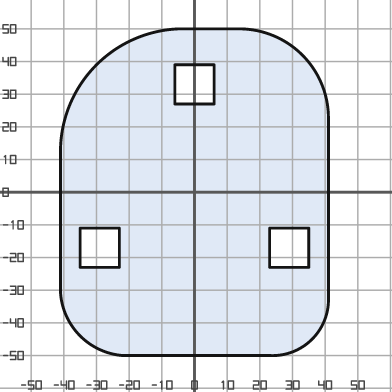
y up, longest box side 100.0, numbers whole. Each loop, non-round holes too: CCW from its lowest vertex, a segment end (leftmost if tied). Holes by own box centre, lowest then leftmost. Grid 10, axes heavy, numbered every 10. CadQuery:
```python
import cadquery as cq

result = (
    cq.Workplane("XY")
    .moveTo(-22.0, -50.0)
    .lineTo(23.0, -50.0)
    .threePointArc((36.0, -45.0), (41.0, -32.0))
    .lineTo(41.0, 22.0)
    .threePointArc((33.0, 42.0), (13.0, 50.0))
    .lineTo(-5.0, 50.0)
    .threePointArc((-30.0, 39.0), (-41.0, 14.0))
    .lineTo(-41.0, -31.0)
    .threePointArc((-35.0, -44.0), (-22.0, -50.0))
    .close()
    .moveTo(-35.0, -23.0)
    .lineTo(-23.0, -23.0)
    .lineTo(-23.0, -11.0)
    .lineTo(-35.0, -11.0)
    .close()
    .moveTo(23.0, -23.0)
    .lineTo(35.0, -23.0)
    .lineTo(35.0, -11.0)
    .lineTo(23.0, -11.0)
    .close()
    .moveTo(-6.0, 27.0)
    .lineTo(6.0, 27.0)
    .lineTo(6.0, 39.0)
    .lineTo(-6.0, 39.0)
    .close()
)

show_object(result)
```